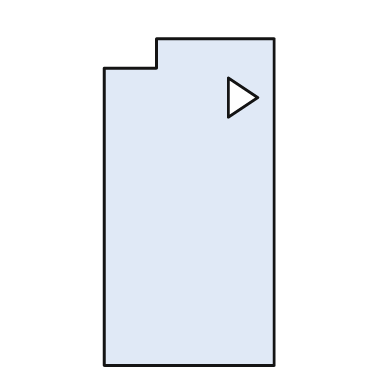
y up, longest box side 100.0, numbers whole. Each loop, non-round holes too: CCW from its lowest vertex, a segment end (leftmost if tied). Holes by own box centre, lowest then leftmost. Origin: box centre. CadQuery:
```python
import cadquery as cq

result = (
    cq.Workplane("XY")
    .moveTo(-26.0, -50.0)
    .lineTo(26.0, -50.0)
    .lineTo(26.0, 50.0)
    .lineTo(-10.0, 50.0)
    .lineTo(-10.0, 41.0)
    .lineTo(-26.0, 41.0)
    .close()
    .moveTo(12.0, 26.0)
    .lineTo(21.0, 32.0)
    .lineTo(12.0, 38.0)
    .close()
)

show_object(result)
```